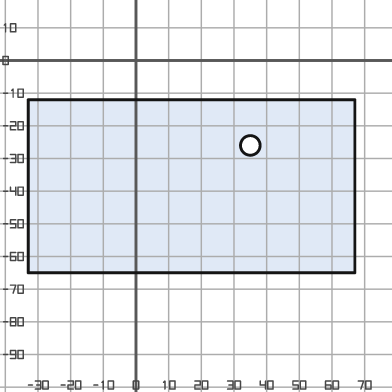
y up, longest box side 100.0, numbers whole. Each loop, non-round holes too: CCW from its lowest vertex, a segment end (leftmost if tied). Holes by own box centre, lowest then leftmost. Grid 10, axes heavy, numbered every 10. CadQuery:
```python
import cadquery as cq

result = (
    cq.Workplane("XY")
    .moveTo(-33.0, -65.0)
    .lineTo(67.0, -65.0)
    .lineTo(67.0, -12.0)
    .lineTo(-33.0, -12.0)
    .close()
    .moveTo(35.0, -26.0)
    .circle(3.0)
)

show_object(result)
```